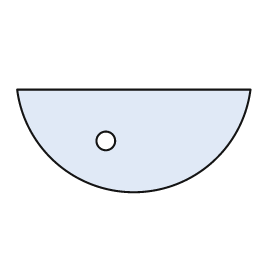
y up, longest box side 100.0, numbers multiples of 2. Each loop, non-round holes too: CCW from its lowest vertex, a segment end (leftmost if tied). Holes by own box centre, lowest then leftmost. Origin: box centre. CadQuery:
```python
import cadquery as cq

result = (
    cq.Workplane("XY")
    .moveTo(-50.0, 22.0)
    .threePointArc((0.0, -22.0), (50.0, 22.0))
    .close()
    .moveTo(-12.0, 0.0)
    .circle(4.0)
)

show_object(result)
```